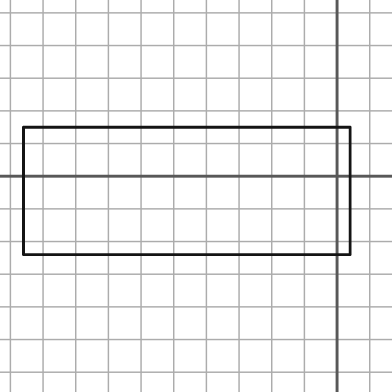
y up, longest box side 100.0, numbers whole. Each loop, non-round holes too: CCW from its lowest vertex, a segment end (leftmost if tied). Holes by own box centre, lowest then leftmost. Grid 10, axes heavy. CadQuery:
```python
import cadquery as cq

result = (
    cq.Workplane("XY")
    .moveTo(-96.0, -24.0)
    .lineTo(4.0, -24.0)
    .lineTo(4.0, 15.0)
    .lineTo(-96.0, 15.0)
    .close()
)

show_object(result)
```